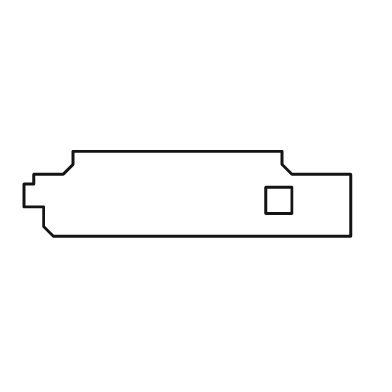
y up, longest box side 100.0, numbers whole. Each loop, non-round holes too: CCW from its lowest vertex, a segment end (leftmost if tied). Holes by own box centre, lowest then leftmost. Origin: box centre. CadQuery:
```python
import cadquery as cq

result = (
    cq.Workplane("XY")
    .moveTo(-41.0, -13.0)
    .lineTo(50.0, -13.0)
    .lineTo(50.0, 6.0)
    .lineTo(32.0, 6.0)
    .lineTo(29.0, 9.0)
    .lineTo(29.0, 13.0)
    .lineTo(-35.0, 13.0)
    .lineTo(-35.0, 9.0)
    .lineTo(-38.0, 6.0)
    .lineTo(-47.0, 6.0)
    .lineTo(-47.0, 3.0)
    .lineTo(-50.0, 3.0)
    .lineTo(-50.0, -4.0)
    .lineTo(-44.0, -4.0)
    .lineTo(-44.0, -10.0)
    .close()
    .moveTo(24.0, -6.0)
    .lineTo(32.0, -6.0)
    .lineTo(32.0, 2.0)
    .lineTo(24.0, 2.0)
    .close()
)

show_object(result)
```